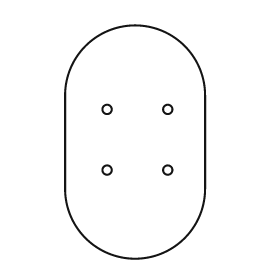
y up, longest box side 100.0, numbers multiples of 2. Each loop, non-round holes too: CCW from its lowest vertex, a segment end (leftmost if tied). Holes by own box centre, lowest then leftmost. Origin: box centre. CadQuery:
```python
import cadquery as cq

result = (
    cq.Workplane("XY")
    .moveTo(-30.0, -20.0)
    .threePointArc((0.0, -50.0), (30.0, -20.0))
    .lineTo(30.0, 20.0)
    .threePointArc((0.0, 50.0), (-30.0, 20.0))
    .close()
    .moveTo(-12.0, -12.0)
    .circle(2.0)
    .moveTo(14.0, -12.0)
    .circle(2.0)
    .moveTo(-12.0, 14.0)
    .circle(2.0)
    .moveTo(14.0, 14.0)
    .circle(2.0)
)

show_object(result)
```